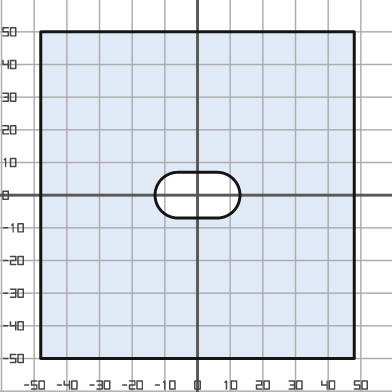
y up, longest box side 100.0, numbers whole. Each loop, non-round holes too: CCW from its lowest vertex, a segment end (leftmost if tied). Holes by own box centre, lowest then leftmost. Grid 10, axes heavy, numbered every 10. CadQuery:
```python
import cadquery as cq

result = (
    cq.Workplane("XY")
    .moveTo(-48.0, -50.0)
    .lineTo(48.0, -50.0)
    .lineTo(48.0, 50.0)
    .lineTo(-48.0, 50.0)
    .close()
    .moveTo(-6.0, -7.0)
    .lineTo(6.0, -7.0)
    .threePointArc((13.0, 0.0), (6.0, 7.0))
    .lineTo(-6.0, 7.0)
    .threePointArc((-13.0, 0.0), (-6.0, -7.0))
    .close()
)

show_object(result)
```